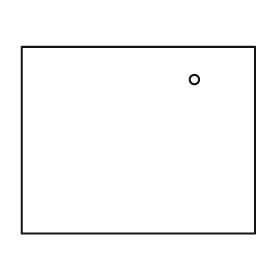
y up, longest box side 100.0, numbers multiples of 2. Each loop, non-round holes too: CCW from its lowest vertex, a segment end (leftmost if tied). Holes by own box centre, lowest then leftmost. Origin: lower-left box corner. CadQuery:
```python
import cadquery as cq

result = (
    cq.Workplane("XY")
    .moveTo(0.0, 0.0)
    .lineTo(100.0, 0.0)
    .lineTo(100.0, 80.0)
    .lineTo(0.0, 80.0)
    .close()
    .moveTo(74.0, 66.0)
    .circle(2.0)
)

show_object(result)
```